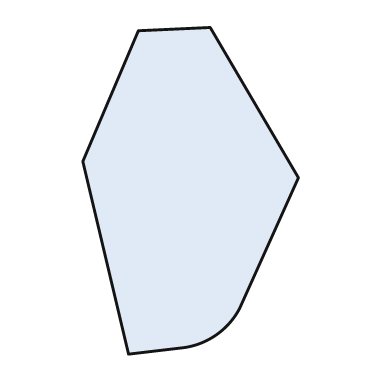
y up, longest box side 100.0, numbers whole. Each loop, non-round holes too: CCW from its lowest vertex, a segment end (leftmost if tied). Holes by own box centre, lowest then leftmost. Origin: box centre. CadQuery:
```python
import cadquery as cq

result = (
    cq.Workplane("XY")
    .moveTo(-19.0, -50.0)
    .lineTo(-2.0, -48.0)
    .threePointArc((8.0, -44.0), (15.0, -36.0))
    .lineTo(33.0, 4.0)
    .lineTo(6.0, 50.0)
    .lineTo(-16.0, 49.0)
    .lineTo(-33.0, 9.0)
    .close()
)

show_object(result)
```